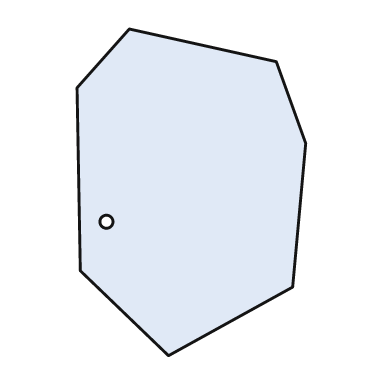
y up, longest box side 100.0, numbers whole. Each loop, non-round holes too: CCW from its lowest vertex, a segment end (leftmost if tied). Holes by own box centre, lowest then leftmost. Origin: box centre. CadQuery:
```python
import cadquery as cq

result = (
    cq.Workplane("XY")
    .moveTo(-7.0, -50.0)
    .lineTo(31.0, -29.0)
    .lineTo(35.0, 15.0)
    .lineTo(26.0, 40.0)
    .lineTo(-19.0, 50.0)
    .lineTo(-35.0, 32.0)
    .lineTo(-34.0, -24.0)
    .close()
    .moveTo(-26.0, -9.0)
    .circle(2.0)
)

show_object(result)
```